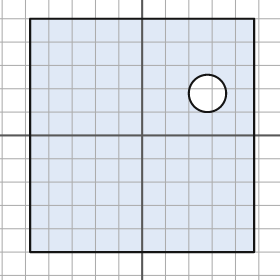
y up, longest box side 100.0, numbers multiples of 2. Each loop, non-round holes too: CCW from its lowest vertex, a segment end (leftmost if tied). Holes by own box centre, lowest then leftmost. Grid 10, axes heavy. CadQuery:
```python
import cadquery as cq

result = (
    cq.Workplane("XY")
    .moveTo(-48.0, -50.0)
    .lineTo(48.0, -50.0)
    .lineTo(48.0, 50.0)
    .lineTo(-48.0, 50.0)
    .close()
    .moveTo(28.0, 18.0)
    .circle(8.0)
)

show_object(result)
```